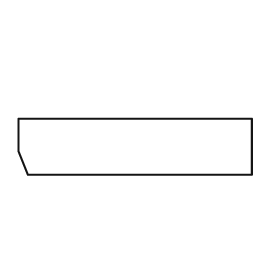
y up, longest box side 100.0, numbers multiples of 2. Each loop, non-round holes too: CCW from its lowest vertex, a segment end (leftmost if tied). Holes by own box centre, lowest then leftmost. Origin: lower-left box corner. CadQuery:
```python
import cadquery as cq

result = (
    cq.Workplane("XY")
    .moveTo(4.0, 0.0)
    .lineTo(100.0, 0.0)
    .lineTo(100.0, 24.0)
    .lineTo(0.0, 24.0)
    .lineTo(0.0, 10.0)
    .close()
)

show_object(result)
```